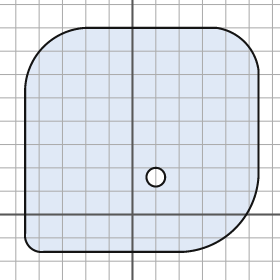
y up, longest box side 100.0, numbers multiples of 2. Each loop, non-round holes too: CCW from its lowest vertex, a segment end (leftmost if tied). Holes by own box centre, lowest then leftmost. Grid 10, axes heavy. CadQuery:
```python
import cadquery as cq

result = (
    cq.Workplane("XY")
    .moveTo(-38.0, -16.0)
    .lineTo(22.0, -16.0)
    .threePointArc((44.0, -6.0), (54.0, 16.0))
    .lineTo(54.0, 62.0)
    .threePointArc((48.0, 74.0), (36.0, 80.0))
    .lineTo(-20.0, 80.0)
    .threePointArc((-38.0, 72.0), (-46.0, 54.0))
    .lineTo(-46.0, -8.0)
    .threePointArc((-44.0, -14.0), (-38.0, -16.0))
    .close()
    .moveTo(10.0, 16.0)
    .circle(4.0)
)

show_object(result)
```